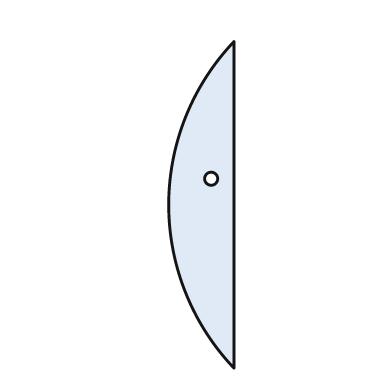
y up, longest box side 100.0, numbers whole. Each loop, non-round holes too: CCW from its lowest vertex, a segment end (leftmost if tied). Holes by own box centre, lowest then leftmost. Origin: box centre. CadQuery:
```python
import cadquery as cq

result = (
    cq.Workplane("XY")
    .moveTo(10.0, -50.0)
    .lineTo(10.0, 50.0)
    .threePointArc((-10.0, 0.0), (10.0, -50.0))
    .close()
    .moveTo(3.0, 8.0)
    .circle(2.0)
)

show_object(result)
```